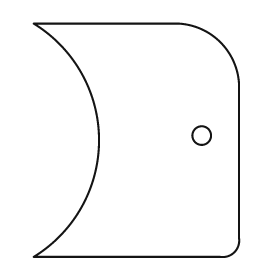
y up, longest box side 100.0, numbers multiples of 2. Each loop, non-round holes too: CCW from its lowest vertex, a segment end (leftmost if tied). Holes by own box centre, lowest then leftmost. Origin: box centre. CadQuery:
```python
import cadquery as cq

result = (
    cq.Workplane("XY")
    .moveTo(-44.0, -50.0)
    .lineTo(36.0, -50.0)
    .threePointArc((42.0, -48.0), (44.0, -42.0))
    .lineTo(44.0, 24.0)
    .threePointArc((36.0, 42.0), (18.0, 50.0))
    .lineTo(-44.0, 50.0)
    .threePointArc((-16.0, 0.0), (-44.0, -50.0))
    .close()
    .moveTo(28.0, 2.0)
    .circle(4.0)
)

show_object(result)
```